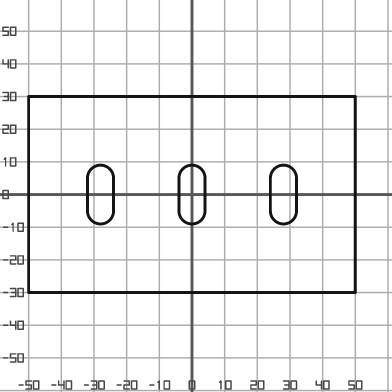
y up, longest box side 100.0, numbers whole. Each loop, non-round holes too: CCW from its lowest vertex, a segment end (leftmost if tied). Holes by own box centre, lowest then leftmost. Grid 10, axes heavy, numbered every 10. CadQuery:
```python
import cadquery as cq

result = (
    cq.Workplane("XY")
    .moveTo(-50.0, -30.0)
    .lineTo(50.0, -30.0)
    .lineTo(50.0, 30.0)
    .lineTo(-50.0, 30.0)
    .close()
    .moveTo(-32.0, -5.0)
    .threePointArc((-28.0, -9.0), (-24.0, -5.0))
    .lineTo(-24.0, 5.0)
    .threePointArc((-28.0, 9.0), (-32.0, 5.0))
    .close()
    .moveTo(-4.0, -5.0)
    .threePointArc((0.0, -9.0), (4.0, -5.0))
    .lineTo(4.0, 5.0)
    .threePointArc((0.0, 9.0), (-4.0, 5.0))
    .close()
    .moveTo(24.0, -5.0)
    .threePointArc((28.0, -9.0), (32.0, -5.0))
    .lineTo(32.0, 5.0)
    .threePointArc((28.0, 9.0), (24.0, 5.0))
    .close()
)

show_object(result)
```